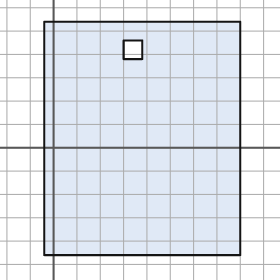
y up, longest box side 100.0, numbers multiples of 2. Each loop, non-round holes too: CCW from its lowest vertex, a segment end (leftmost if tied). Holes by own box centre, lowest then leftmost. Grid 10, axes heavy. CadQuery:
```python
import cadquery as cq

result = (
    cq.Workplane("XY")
    .moveTo(-4.0, -46.0)
    .lineTo(80.0, -46.0)
    .lineTo(80.0, 54.0)
    .lineTo(-4.0, 54.0)
    .close()
    .moveTo(30.0, 38.0)
    .lineTo(38.0, 38.0)
    .lineTo(38.0, 46.0)
    .lineTo(30.0, 46.0)
    .close()
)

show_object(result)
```